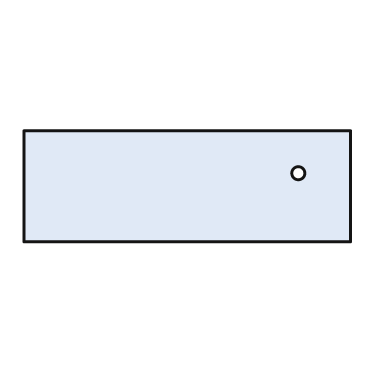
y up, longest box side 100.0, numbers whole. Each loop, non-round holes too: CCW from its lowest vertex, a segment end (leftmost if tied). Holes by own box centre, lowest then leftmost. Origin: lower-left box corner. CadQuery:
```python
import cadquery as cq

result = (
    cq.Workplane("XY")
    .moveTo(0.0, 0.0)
    .lineTo(100.0, 0.0)
    .lineTo(100.0, 34.0)
    .lineTo(0.0, 34.0)
    .close()
    .moveTo(84.0, 21.0)
    .circle(2.0)
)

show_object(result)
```